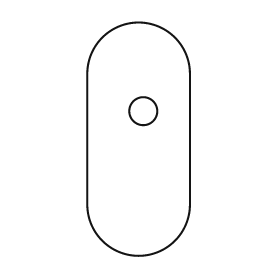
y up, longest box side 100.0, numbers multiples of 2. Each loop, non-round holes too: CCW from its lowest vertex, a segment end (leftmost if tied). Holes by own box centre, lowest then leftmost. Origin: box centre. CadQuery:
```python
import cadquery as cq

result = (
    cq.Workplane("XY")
    .moveTo(-22.0, -28.0)
    .threePointArc((0.0, -50.0), (22.0, -28.0))
    .lineTo(22.0, 28.0)
    .threePointArc((0.0, 50.0), (-22.0, 28.0))
    .close()
    .moveTo(2.0, 12.0)
    .circle(6.0)
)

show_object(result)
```